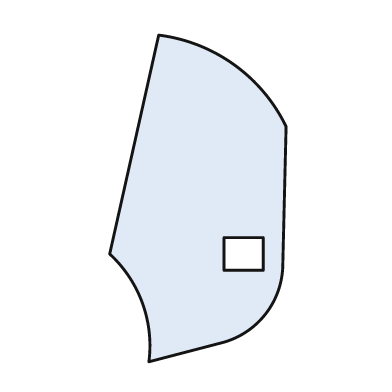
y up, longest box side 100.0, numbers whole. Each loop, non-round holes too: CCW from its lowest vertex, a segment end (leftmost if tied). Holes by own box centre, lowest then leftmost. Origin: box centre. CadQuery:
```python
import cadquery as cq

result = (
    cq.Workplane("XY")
    .moveTo(-15.0, -50.0)
    .lineTo(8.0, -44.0)
    .threePointArc((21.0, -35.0), (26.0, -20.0))
    .lineTo(27.0, 22.0)
    .threePointArc((11.0, 41.0), (-12.0, 50.0))
    .lineTo(-27.0, -17.0)
    .threePointArc((-17.0, -32.0), (-15.0, -50.0))
    .close()
    .moveTo(8.0, -22.0)
    .lineTo(20.0, -22.0)
    .lineTo(20.0, -12.0)
    .lineTo(8.0, -12.0)
    .close()
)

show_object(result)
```